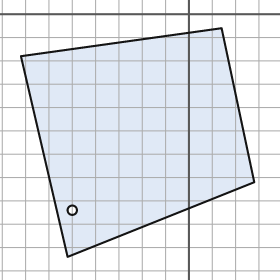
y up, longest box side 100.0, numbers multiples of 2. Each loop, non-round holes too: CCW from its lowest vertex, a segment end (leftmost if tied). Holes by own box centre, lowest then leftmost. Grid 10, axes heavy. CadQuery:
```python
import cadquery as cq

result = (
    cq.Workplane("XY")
    .moveTo(-52.0, -104.0)
    .lineTo(28.0, -72.0)
    .lineTo(14.0, -6.0)
    .lineTo(-72.0, -18.0)
    .close()
    .moveTo(-50.0, -84.0)
    .circle(2.0)
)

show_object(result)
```